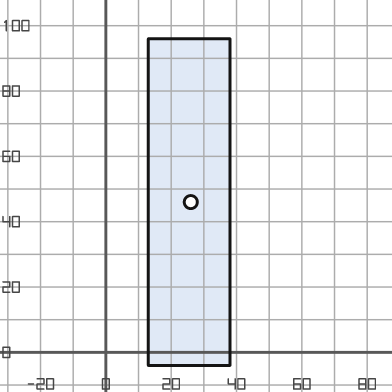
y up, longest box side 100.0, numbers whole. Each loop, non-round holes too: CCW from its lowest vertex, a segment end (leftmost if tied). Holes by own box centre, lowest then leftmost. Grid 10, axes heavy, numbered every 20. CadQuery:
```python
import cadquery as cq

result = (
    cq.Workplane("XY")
    .moveTo(13.0, -4.0)
    .lineTo(38.0, -4.0)
    .lineTo(38.0, 96.0)
    .lineTo(13.0, 96.0)
    .close()
    .moveTo(26.0, 46.0)
    .circle(2.0)
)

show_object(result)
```